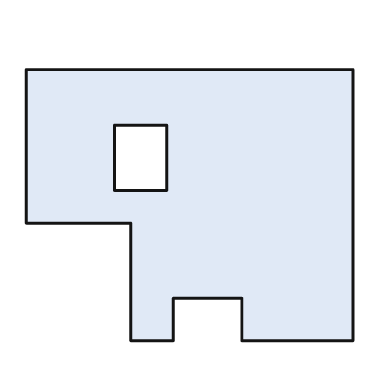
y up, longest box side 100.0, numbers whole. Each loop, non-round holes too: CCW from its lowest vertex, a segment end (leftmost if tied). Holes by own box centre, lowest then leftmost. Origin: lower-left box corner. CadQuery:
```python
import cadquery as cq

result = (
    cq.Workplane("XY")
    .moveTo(32.0, 0.0)
    .lineTo(45.0, 0.0)
    .lineTo(45.0, 13.0)
    .lineTo(66.0, 13.0)
    .lineTo(66.0, 0.0)
    .lineTo(100.0, 0.0)
    .lineTo(100.0, 83.0)
    .lineTo(0.0, 83.0)
    .lineTo(0.0, 36.0)
    .lineTo(32.0, 36.0)
    .close()
    .moveTo(27.0, 46.0)
    .lineTo(43.0, 46.0)
    .lineTo(43.0, 66.0)
    .lineTo(27.0, 66.0)
    .close()
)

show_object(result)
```